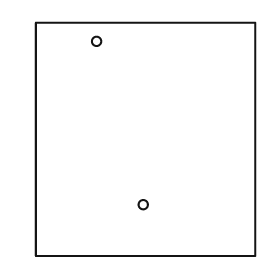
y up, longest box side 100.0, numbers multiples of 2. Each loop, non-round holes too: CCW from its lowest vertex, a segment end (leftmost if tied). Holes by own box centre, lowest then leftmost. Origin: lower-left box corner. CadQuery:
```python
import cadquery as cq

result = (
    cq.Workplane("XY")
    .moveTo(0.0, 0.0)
    .lineTo(94.0, 0.0)
    .lineTo(94.0, 100.0)
    .lineTo(0.0, 100.0)
    .close()
    .moveTo(46.0, 22.0)
    .circle(2.0)
    .moveTo(26.0, 92.0)
    .circle(2.0)
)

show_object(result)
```